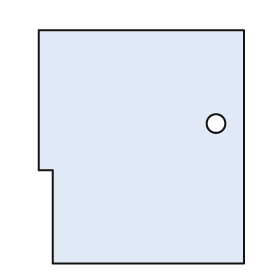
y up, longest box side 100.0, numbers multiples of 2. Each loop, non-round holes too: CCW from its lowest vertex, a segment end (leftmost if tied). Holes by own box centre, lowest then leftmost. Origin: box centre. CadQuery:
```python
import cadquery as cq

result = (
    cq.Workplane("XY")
    .moveTo(-38.0, -50.0)
    .lineTo(44.0, -50.0)
    .lineTo(44.0, 50.0)
    .lineTo(-44.0, 50.0)
    .lineTo(-44.0, -10.0)
    .lineTo(-38.0, -10.0)
    .close()
    .moveTo(32.0, 10.0)
    .circle(4.0)
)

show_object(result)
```